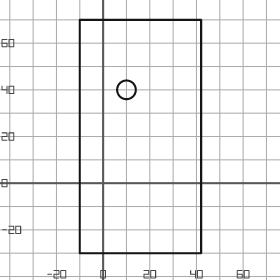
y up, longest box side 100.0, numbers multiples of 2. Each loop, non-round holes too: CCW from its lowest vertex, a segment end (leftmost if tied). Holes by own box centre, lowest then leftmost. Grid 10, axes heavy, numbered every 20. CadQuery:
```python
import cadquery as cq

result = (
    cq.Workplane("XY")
    .moveTo(-10.0, -30.0)
    .lineTo(42.0, -30.0)
    .lineTo(42.0, 70.0)
    .lineTo(-10.0, 70.0)
    .close()
    .moveTo(10.0, 40.0)
    .circle(4.0)
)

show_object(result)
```